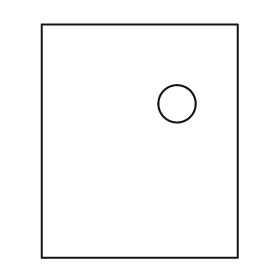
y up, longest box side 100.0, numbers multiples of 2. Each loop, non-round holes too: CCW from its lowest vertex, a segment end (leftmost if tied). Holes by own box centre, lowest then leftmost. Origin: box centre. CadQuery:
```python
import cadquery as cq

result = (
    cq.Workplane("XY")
    .moveTo(-42.0, -50.0)
    .lineTo(42.0, -50.0)
    .lineTo(42.0, 50.0)
    .lineTo(-42.0, 50.0)
    .close()
    .moveTo(16.0, 16.0)
    .circle(8.0)
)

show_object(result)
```